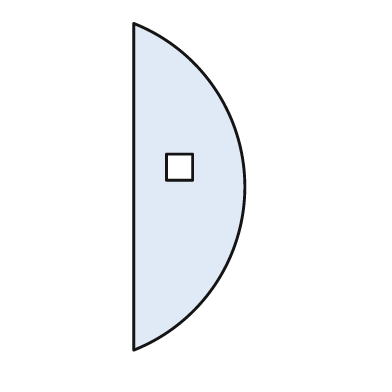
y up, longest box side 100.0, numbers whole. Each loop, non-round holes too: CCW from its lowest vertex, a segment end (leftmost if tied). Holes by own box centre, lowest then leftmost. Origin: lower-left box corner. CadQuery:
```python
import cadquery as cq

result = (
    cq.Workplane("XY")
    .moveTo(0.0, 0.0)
    .threePointArc((34.0, 50.0), (0.0, 100.0))
    .close()
    .moveTo(10.0, 52.0)
    .lineTo(18.0, 52.0)
    .lineTo(18.0, 60.0)
    .lineTo(10.0, 60.0)
    .close()
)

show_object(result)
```